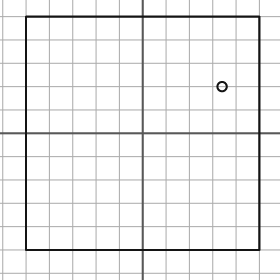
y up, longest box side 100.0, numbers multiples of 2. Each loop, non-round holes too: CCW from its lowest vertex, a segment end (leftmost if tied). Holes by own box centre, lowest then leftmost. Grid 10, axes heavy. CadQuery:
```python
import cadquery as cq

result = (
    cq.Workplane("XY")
    .moveTo(-50.0, -50.0)
    .lineTo(50.0, -50.0)
    .lineTo(50.0, 50.0)
    .lineTo(-50.0, 50.0)
    .close()
    .moveTo(34.0, 20.0)
    .circle(2.0)
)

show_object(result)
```